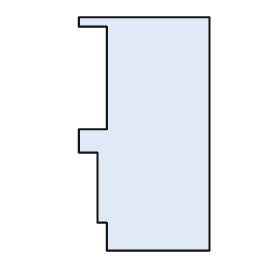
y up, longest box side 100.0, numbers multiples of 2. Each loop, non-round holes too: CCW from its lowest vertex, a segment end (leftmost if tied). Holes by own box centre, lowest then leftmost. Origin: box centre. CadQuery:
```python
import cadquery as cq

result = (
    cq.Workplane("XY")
    .moveTo(-16.0, -50.0)
    .lineTo(28.0, -50.0)
    .lineTo(28.0, 50.0)
    .lineTo(-28.0, 50.0)
    .lineTo(-28.0, 46.0)
    .lineTo(-16.0, 46.0)
    .lineTo(-16.0, 2.0)
    .lineTo(-28.0, 2.0)
    .lineTo(-28.0, -8.0)
    .lineTo(-20.0, -8.0)
    .lineTo(-20.0, -38.0)
    .lineTo(-16.0, -38.0)
    .close()
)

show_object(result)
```